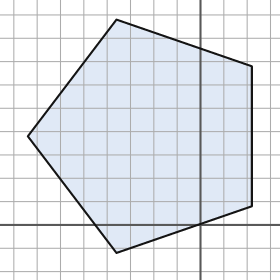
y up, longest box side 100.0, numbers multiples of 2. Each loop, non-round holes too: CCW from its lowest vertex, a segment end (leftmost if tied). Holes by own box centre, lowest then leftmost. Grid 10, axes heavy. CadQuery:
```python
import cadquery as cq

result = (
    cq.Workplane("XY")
    .moveTo(-36.0, -12.0)
    .lineTo(22.0, 8.0)
    .lineTo(22.0, 68.0)
    .lineTo(-36.0, 88.0)
    .lineTo(-74.0, 38.0)
    .close()
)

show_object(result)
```